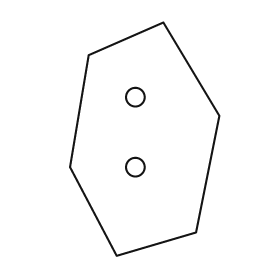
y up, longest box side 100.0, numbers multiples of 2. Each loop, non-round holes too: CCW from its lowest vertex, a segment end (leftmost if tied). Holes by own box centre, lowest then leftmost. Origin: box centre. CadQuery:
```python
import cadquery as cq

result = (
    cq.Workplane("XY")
    .moveTo(-12.0, -50.0)
    .lineTo(22.0, -40.0)
    .lineTo(32.0, 10.0)
    .lineTo(8.0, 50.0)
    .lineTo(-24.0, 36.0)
    .lineTo(-32.0, -12.0)
    .close()
    .moveTo(-4.0, -12.0)
    .circle(4.0)
    .moveTo(-4.0, 18.0)
    .circle(4.0)
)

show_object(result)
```